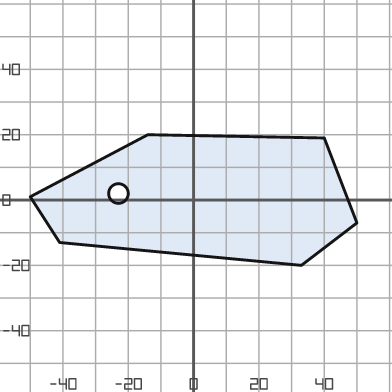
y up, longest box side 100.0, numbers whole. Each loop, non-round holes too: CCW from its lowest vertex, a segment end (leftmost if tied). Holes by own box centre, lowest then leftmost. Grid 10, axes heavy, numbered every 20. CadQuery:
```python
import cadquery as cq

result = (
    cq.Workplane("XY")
    .moveTo(33.0, -20.0)
    .lineTo(50.0, -7.0)
    .lineTo(40.0, 19.0)
    .lineTo(-14.0, 20.0)
    .lineTo(-50.0, 1.0)
    .lineTo(-41.0, -13.0)
    .close()
    .moveTo(-23.0, 2.0)
    .circle(3.0)
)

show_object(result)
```